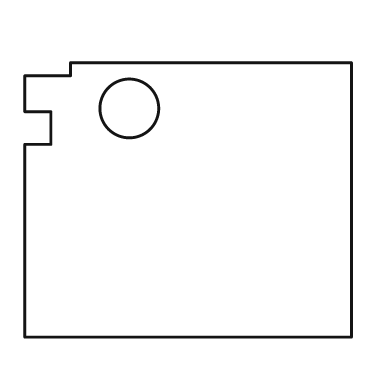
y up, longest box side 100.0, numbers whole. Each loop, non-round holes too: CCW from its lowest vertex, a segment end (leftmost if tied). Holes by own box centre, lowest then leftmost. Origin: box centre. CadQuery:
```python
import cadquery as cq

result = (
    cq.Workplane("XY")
    .moveTo(-50.0, -42.0)
    .lineTo(50.0, -42.0)
    .lineTo(50.0, 42.0)
    .lineTo(-36.0, 42.0)
    .lineTo(-36.0, 38.0)
    .lineTo(-50.0, 38.0)
    .lineTo(-50.0, 27.0)
    .lineTo(-42.0, 27.0)
    .lineTo(-42.0, 17.0)
    .lineTo(-50.0, 17.0)
    .close()
    .moveTo(-18.0, 28.0)
    .circle(9.0)
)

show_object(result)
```